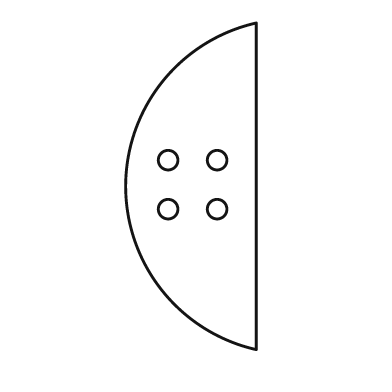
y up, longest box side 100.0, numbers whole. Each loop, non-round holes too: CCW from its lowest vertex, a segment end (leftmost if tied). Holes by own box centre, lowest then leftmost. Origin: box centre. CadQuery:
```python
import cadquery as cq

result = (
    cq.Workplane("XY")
    .moveTo(20.0, -50.0)
    .lineTo(20.0, 50.0)
    .threePointArc((-20.0, 0.0), (20.0, -50.0))
    .close()
    .moveTo(-7.0, -7.0)
    .circle(3.0)
    .moveTo(8.0, -7.0)
    .circle(3.0)
    .moveTo(-7.0, 8.0)
    .circle(3.0)
    .moveTo(8.0, 8.0)
    .circle(3.0)
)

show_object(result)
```